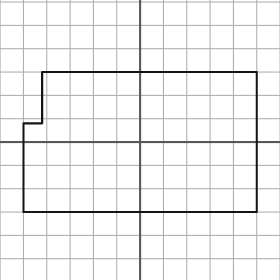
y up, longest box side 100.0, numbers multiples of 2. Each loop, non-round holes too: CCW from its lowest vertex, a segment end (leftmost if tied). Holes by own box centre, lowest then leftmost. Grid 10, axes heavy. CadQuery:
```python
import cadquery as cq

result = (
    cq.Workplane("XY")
    .moveTo(-50.0, -30.0)
    .lineTo(50.0, -30.0)
    .lineTo(50.0, 30.0)
    .lineTo(-42.0, 30.0)
    .lineTo(-42.0, 8.0)
    .lineTo(-50.0, 8.0)
    .close()
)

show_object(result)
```